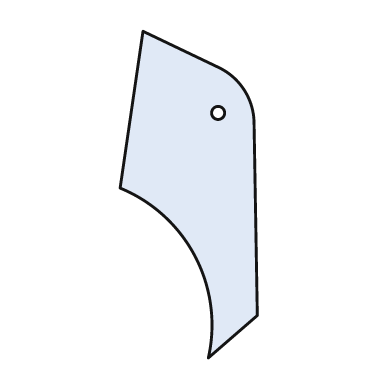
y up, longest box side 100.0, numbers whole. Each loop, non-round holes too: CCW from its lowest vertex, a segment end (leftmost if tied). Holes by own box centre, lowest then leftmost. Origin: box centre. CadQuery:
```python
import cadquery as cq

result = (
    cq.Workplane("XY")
    .moveTo(6.0, -50.0)
    .lineTo(21.0, -37.0)
    .lineTo(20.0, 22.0)
    .threePointArc((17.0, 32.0), (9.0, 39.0))
    .lineTo(-14.0, 50.0)
    .lineTo(-21.0, 2.0)
    .threePointArc((2.0, -19.0), (6.0, -50.0))
    .close()
    .moveTo(9.0, 25.0)
    .circle(2.0)
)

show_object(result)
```